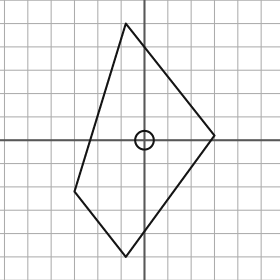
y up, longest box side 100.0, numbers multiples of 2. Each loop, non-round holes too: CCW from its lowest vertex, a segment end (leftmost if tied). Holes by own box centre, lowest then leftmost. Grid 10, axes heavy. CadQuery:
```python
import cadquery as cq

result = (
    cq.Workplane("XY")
    .moveTo(-8.0, -50.0)
    .lineTo(30.0, 2.0)
    .lineTo(-8.0, 50.0)
    .lineTo(-30.0, -22.0)
    .close()
    .moveTo(0.0, 0.0)
    .circle(4.0)
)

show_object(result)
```